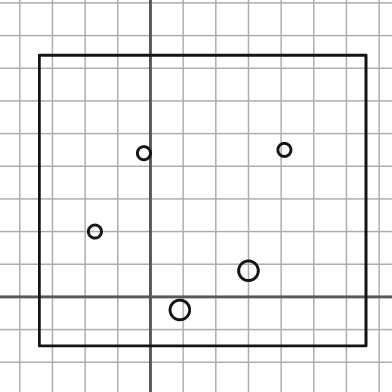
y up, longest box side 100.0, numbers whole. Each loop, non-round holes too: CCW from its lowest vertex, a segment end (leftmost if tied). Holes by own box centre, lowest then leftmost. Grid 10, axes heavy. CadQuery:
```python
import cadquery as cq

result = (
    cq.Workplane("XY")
    .moveTo(-34.0, -15.0)
    .lineTo(66.0, -15.0)
    .lineTo(66.0, 74.0)
    .lineTo(-34.0, 74.0)
    .close()
    .moveTo(9.0, -4.0)
    .circle(3.0)
    .moveTo(30.0, 8.0)
    .circle(3.0)
    .moveTo(-17.0, 20.0)
    .circle(2.0)
    .moveTo(-2.0, 44.0)
    .circle(2.0)
    .moveTo(41.0, 45.0)
    .circle(2.0)
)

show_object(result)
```